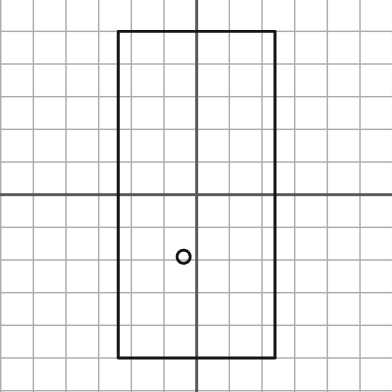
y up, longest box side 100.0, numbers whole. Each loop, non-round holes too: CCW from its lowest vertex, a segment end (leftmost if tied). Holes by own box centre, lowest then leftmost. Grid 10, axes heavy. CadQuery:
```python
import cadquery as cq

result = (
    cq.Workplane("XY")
    .moveTo(-24.0, -50.0)
    .lineTo(24.0, -50.0)
    .lineTo(24.0, 50.0)
    .lineTo(-24.0, 50.0)
    .close()
    .moveTo(-4.0, -19.0)
    .circle(2.0)
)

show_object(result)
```